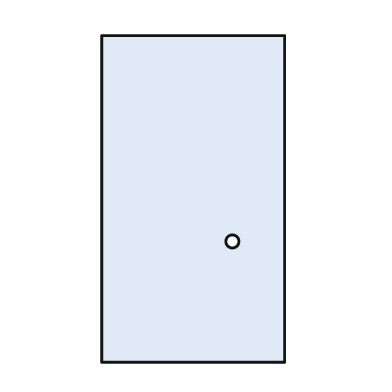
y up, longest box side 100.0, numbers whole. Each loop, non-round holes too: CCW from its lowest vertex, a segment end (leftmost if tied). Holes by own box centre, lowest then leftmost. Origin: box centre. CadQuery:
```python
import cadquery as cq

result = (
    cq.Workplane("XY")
    .moveTo(-28.0, -50.0)
    .lineTo(28.0, -50.0)
    .lineTo(28.0, 50.0)
    .lineTo(-28.0, 50.0)
    .close()
    .moveTo(12.0, -13.0)
    .circle(2.0)
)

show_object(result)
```